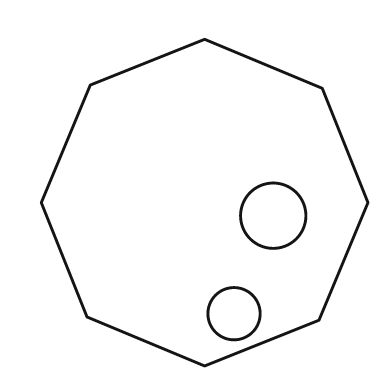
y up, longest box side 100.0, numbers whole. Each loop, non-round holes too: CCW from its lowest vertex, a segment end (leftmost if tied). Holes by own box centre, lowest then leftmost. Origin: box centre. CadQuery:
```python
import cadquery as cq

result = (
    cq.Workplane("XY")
    .moveTo(0.0, -50.0)
    .lineTo(35.0, -36.0)
    .lineTo(50.0, 0.0)
    .lineTo(36.0, 35.0)
    .lineTo(0.0, 50.0)
    .lineTo(-35.0, 36.0)
    .lineTo(-50.0, 0.0)
    .lineTo(-36.0, -35.0)
    .close()
    .moveTo(9.0, -34.0)
    .circle(8.0)
    .moveTo(21.0, -4.0)
    .circle(10.0)
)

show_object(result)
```